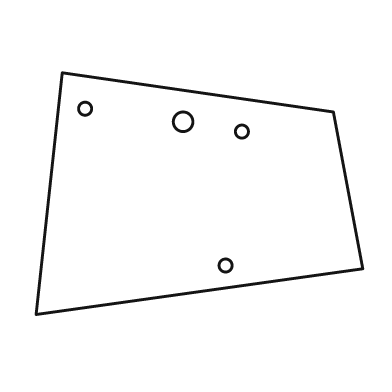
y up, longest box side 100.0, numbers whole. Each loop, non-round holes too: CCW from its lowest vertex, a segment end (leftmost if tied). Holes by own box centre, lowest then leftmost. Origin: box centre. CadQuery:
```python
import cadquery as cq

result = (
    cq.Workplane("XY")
    .moveTo(-50.0, -37.0)
    .lineTo(50.0, -23.0)
    .lineTo(41.0, 25.0)
    .lineTo(-42.0, 37.0)
    .close()
    .moveTo(8.0, -22.0)
    .circle(2.0)
    .moveTo(13.0, 19.0)
    .circle(2.0)
    .moveTo(-5.0, 22.0)
    .circle(3.0)
    .moveTo(-35.0, 26.0)
    .circle(2.0)
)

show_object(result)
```